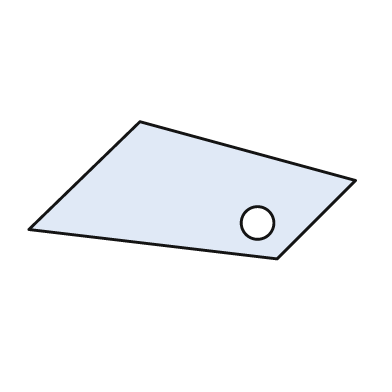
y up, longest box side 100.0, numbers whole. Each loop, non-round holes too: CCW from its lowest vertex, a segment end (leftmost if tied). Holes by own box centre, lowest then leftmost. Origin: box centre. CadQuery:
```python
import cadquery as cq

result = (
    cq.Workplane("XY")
    .moveTo(26.0, -21.0)
    .lineTo(50.0, 3.0)
    .lineTo(-16.0, 21.0)
    .lineTo(-50.0, -12.0)
    .close()
    .moveTo(20.0, -10.0)
    .circle(5.0)
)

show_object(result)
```